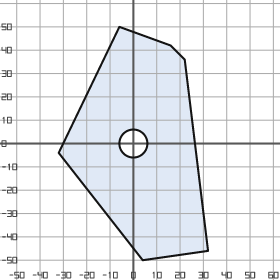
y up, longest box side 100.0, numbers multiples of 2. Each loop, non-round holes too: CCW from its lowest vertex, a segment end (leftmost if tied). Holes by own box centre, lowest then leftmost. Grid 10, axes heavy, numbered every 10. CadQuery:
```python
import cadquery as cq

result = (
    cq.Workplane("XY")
    .moveTo(4.0, -50.0)
    .lineTo(32.0, -46.0)
    .lineTo(22.0, 36.0)
    .lineTo(16.0, 42.0)
    .lineTo(-6.0, 50.0)
    .lineTo(-32.0, -4.0)
    .close()
    .moveTo(0.0, 0.0)
    .circle(6.0)
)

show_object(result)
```